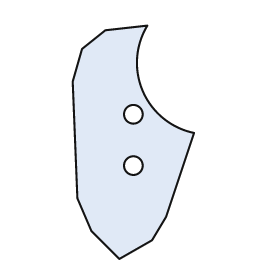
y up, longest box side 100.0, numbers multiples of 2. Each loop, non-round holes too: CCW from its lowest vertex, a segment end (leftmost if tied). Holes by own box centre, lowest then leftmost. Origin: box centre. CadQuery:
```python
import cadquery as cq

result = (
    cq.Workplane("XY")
    .moveTo(-6.0, -50.0)
    .lineTo(8.0, -42.0)
    .lineTo(14.0, -32.0)
    .lineTo(26.0, 4.0)
    .threePointArc((4.0, 22.0), (6.0, 50.0))
    .lineTo(-12.0, 48.0)
    .lineTo(-22.0, 40.0)
    .lineTo(-26.0, 26.0)
    .lineTo(-24.0, -24.0)
    .lineTo(-18.0, -38.0)
    .close()
    .moveTo(0.0, -10.0)
    .circle(4.0)
    .moveTo(0.0, 12.0)
    .circle(4.0)
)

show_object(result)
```